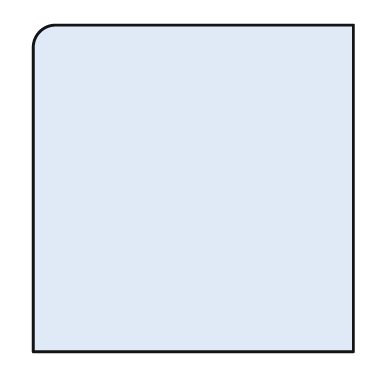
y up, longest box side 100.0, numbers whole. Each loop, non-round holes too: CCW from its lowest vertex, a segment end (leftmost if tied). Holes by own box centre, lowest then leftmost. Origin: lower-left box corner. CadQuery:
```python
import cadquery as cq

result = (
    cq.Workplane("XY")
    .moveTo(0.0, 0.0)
    .lineTo(98.0, 0.0)
    .lineTo(98.0, 100.0)
    .lineTo(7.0, 100.0)
    .threePointArc((2.0, 98.0), (0.0, 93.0))
    .close()
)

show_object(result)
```